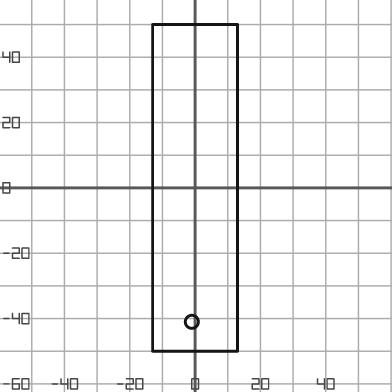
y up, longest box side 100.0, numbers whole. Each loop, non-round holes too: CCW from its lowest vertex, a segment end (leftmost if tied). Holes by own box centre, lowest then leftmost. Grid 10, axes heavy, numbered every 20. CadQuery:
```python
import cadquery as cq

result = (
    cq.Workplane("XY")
    .moveTo(-13.0, -50.0)
    .lineTo(13.0, -50.0)
    .lineTo(13.0, 50.0)
    .lineTo(-13.0, 50.0)
    .close()
    .moveTo(-1.0, -41.0)
    .circle(2.0)
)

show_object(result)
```